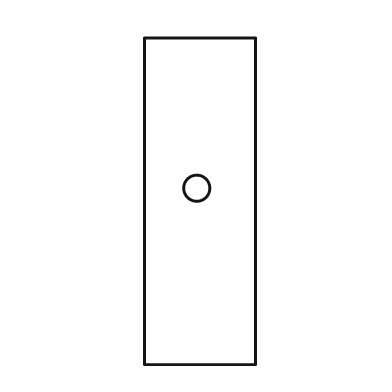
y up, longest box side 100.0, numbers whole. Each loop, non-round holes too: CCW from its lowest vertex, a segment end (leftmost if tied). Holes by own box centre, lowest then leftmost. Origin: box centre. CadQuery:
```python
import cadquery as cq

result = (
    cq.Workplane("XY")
    .moveTo(-17.0, -50.0)
    .lineTo(17.0, -50.0)
    .lineTo(17.0, 50.0)
    .lineTo(-17.0, 50.0)
    .close()
    .moveTo(-1.0, 4.0)
    .circle(4.0)
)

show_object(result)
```